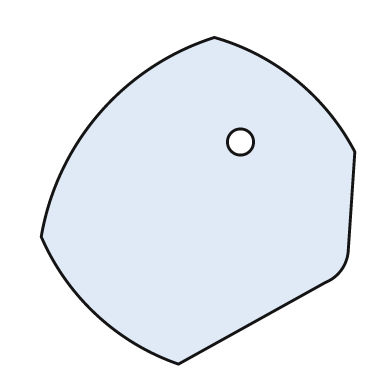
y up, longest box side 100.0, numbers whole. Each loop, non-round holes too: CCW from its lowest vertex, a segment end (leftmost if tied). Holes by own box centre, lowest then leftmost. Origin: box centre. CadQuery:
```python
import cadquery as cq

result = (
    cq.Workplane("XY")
    .moveTo(-6.0, -50.0)
    .lineTo(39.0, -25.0)
    .threePointArc((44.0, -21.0), (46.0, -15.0))
    .lineTo(48.0, 15.0)
    .threePointArc((30.0, 37.0), (5.0, 50.0))
    .threePointArc((-30.0, 27.0), (-48.0, -11.0))
    .threePointArc((-31.0, -35.0), (-6.0, -50.0))
    .close()
    .moveTo(13.0, 18.0)
    .circle(4.0)
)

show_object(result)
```